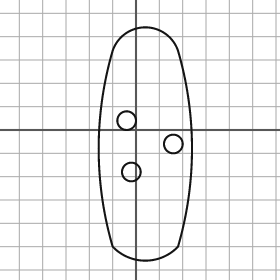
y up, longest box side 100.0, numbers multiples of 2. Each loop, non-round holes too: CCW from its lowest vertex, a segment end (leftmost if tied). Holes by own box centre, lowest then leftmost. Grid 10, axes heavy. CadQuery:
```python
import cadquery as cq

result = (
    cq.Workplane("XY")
    .moveTo(-10.0, -50.0)
    .threePointArc((4.0, -56.0), (18.0, -50.0))
    .threePointArc((24.0, -8.0), (18.0, 34.0))
    .threePointArc((4.0, 44.0), (-10.0, 34.0))
    .threePointArc((-16.0, -8.0), (-10.0, -50.0))
    .close()
    .moveTo(-2.0, -18.0)
    .circle(4.0)
    .moveTo(16.0, -6.0)
    .circle(4.0)
    .moveTo(-4.0, 4.0)
    .circle(4.0)
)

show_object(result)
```